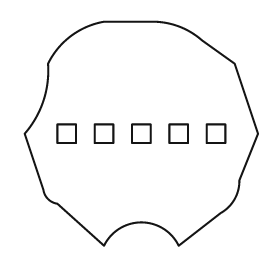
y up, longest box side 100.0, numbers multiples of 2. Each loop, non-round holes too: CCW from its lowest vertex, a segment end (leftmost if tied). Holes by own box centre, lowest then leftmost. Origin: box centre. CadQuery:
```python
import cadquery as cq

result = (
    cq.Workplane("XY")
    .moveTo(-16.0, -48.0)
    .threePointArc((0.0, -38.0), (16.0, -48.0))
    .lineTo(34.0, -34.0)
    .threePointArc((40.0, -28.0), (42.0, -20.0))
    .lineTo(50.0, 0.0)
    .lineTo(40.0, 30.0)
    .lineTo(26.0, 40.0)
    .threePointArc((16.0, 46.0), (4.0, 48.0))
    .lineTo(-16.0, 48.0)
    .threePointArc((-30.0, 42.0), (-40.0, 30.0))
    .threePointArc((-42.0, 14.0), (-50.0, 0.0))
    .lineTo(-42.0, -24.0)
    .threePointArc((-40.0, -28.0), (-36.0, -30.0))
    .close()
    .moveTo(-36.0, -4.0)
    .lineTo(-28.0, -4.0)
    .lineTo(-28.0, 4.0)
    .lineTo(-36.0, 4.0)
    .close()
    .moveTo(-20.0, -4.0)
    .lineTo(-12.0, -4.0)
    .lineTo(-12.0, 4.0)
    .lineTo(-20.0, 4.0)
    .close()
    .moveTo(-4.0, -4.0)
    .lineTo(4.0, -4.0)
    .lineTo(4.0, 4.0)
    .lineTo(-4.0, 4.0)
    .close()
    .moveTo(12.0, -4.0)
    .lineTo(20.0, -4.0)
    .lineTo(20.0, 4.0)
    .lineTo(12.0, 4.0)
    .close()
    .moveTo(28.0, -4.0)
    .lineTo(36.0, -4.0)
    .lineTo(36.0, 4.0)
    .lineTo(28.0, 4.0)
    .close()
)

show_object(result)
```